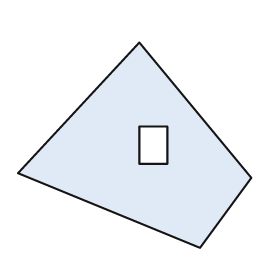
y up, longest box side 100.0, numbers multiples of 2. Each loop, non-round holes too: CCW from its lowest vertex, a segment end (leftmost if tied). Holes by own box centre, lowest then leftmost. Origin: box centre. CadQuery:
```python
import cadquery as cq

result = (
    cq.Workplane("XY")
    .moveTo(28.0, -44.0)
    .lineTo(50.0, -14.0)
    .lineTo(2.0, 44.0)
    .lineTo(-50.0, -12.0)
    .close()
    .moveTo(2.0, -8.0)
    .lineTo(14.0, -8.0)
    .lineTo(14.0, 8.0)
    .lineTo(2.0, 8.0)
    .close()
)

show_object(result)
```